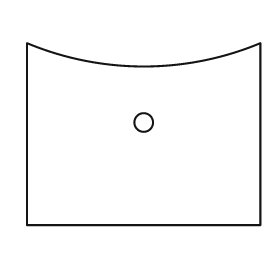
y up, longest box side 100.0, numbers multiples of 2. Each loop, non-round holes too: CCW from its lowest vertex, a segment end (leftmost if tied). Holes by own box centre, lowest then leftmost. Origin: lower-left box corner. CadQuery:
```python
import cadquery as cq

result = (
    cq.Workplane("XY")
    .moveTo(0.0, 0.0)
    .lineTo(100.0, 0.0)
    .lineTo(100.0, 78.0)
    .threePointArc((50.0, 68.0), (0.0, 78.0))
    .close()
    .moveTo(50.0, 44.0)
    .circle(4.0)
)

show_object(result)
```